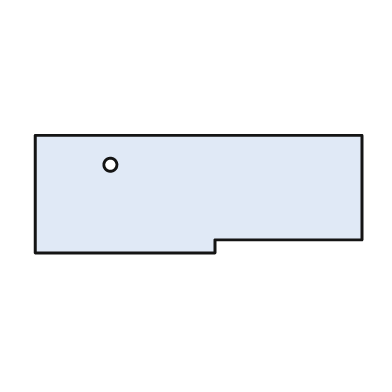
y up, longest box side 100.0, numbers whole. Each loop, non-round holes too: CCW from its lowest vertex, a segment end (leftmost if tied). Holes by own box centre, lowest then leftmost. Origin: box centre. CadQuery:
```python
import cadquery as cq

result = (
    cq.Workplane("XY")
    .moveTo(-50.0, -18.0)
    .lineTo(5.0, -18.0)
    .lineTo(5.0, -14.0)
    .lineTo(50.0, -14.0)
    .lineTo(50.0, 18.0)
    .lineTo(-50.0, 18.0)
    .close()
    .moveTo(-27.0, 9.0)
    .circle(2.0)
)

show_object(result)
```